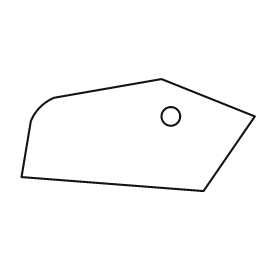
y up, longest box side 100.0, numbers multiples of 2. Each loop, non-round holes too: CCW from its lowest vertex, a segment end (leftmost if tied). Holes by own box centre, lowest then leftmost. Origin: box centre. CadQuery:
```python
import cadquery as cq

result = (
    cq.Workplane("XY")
    .moveTo(28.0, -24.0)
    .lineTo(50.0, 8.0)
    .lineTo(10.0, 24.0)
    .lineTo(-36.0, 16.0)
    .threePointArc((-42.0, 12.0), (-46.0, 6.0))
    .lineTo(-50.0, -18.0)
    .close()
    .moveTo(14.0, 8.0)
    .circle(4.0)
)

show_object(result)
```